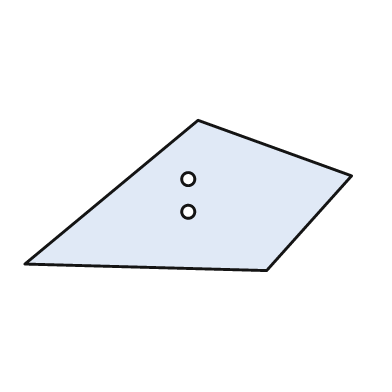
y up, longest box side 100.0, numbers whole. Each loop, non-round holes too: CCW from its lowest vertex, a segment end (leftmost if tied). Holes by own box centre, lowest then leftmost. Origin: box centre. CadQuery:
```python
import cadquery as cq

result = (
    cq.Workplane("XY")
    .moveTo(24.0, -23.0)
    .lineTo(50.0, 6.0)
    .lineTo(3.0, 23.0)
    .lineTo(-50.0, -21.0)
    .close()
    .moveTo(0.0, -5.0)
    .circle(2.0)
    .moveTo(0.0, 5.0)
    .circle(2.0)
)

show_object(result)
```